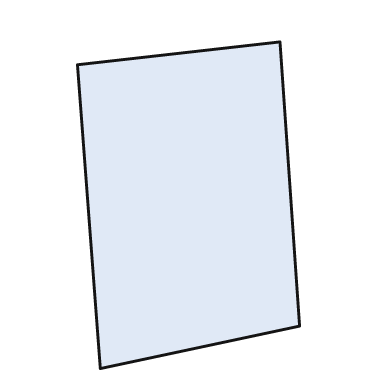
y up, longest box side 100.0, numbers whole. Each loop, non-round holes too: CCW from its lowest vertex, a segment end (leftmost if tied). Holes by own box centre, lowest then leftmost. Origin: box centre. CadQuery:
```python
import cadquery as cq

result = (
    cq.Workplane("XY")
    .moveTo(-27.0, -50.0)
    .lineTo(34.0, -37.0)
    .lineTo(28.0, 50.0)
    .lineTo(-34.0, 43.0)
    .close()
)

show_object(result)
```